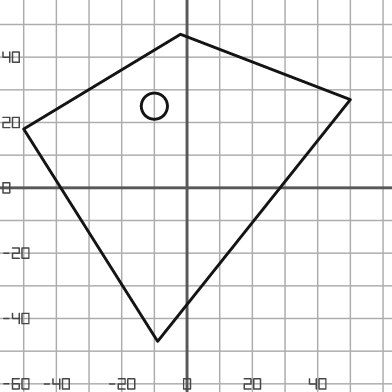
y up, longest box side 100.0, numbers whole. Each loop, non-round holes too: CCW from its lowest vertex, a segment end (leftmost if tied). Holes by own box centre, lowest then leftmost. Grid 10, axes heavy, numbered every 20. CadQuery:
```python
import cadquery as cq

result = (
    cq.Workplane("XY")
    .moveTo(-9.0, -47.0)
    .lineTo(50.0, 27.0)
    .lineTo(-2.0, 47.0)
    .lineTo(-50.0, 18.0)
    .close()
    .moveTo(-10.0, 25.0)
    .circle(4.0)
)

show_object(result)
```